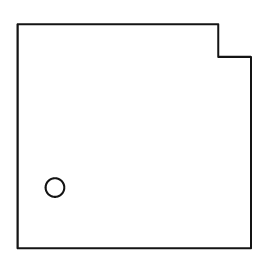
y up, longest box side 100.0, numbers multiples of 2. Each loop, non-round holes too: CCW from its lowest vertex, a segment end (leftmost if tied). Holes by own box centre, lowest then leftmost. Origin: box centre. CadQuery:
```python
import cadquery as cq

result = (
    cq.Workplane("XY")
    .moveTo(-50.0, -48.0)
    .lineTo(50.0, -48.0)
    .lineTo(50.0, 34.0)
    .lineTo(36.0, 34.0)
    .lineTo(36.0, 48.0)
    .lineTo(-50.0, 48.0)
    .close()
    .moveTo(-34.0, -22.0)
    .circle(4.0)
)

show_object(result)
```